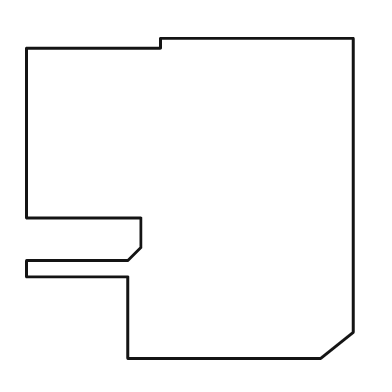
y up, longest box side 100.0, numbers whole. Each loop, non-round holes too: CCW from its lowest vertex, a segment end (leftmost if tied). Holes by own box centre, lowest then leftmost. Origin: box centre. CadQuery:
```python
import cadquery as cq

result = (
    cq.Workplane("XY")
    .moveTo(-19.0, -49.0)
    .lineTo(40.0, -49.0)
    .lineTo(50.0, -41.0)
    .lineTo(50.0, 49.0)
    .lineTo(-9.0, 49.0)
    .lineTo(-9.0, 46.0)
    .lineTo(-50.0, 46.0)
    .lineTo(-50.0, -6.0)
    .lineTo(-15.0, -6.0)
    .lineTo(-15.0, -15.0)
    .lineTo(-19.0, -19.0)
    .lineTo(-50.0, -19.0)
    .lineTo(-50.0, -24.0)
    .lineTo(-19.0, -24.0)
    .close()
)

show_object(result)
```